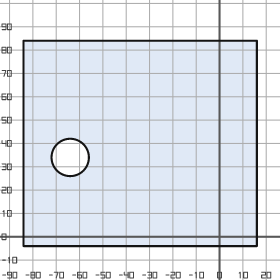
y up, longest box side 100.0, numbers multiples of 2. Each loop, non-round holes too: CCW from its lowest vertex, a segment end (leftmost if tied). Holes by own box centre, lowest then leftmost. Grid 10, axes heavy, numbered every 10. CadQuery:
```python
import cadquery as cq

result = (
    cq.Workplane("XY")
    .moveTo(-84.0, -4.0)
    .lineTo(16.0, -4.0)
    .lineTo(16.0, 84.0)
    .lineTo(-84.0, 84.0)
    .close()
    .moveTo(-64.0, 34.0)
    .circle(8.0)
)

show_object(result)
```